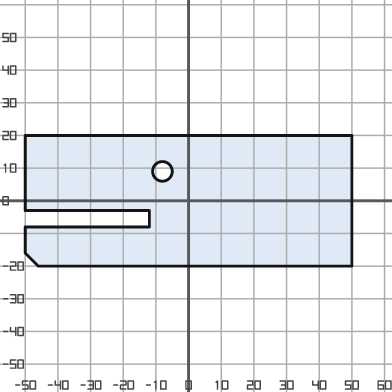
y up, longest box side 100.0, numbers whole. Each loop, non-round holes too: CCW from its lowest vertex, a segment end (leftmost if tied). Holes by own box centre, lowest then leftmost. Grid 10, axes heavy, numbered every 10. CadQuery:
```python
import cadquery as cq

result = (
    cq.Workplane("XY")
    .moveTo(-46.0, -20.0)
    .lineTo(50.0, -20.0)
    .lineTo(50.0, 20.0)
    .lineTo(-50.0, 20.0)
    .lineTo(-50.0, -3.0)
    .lineTo(-12.0, -3.0)
    .lineTo(-12.0, -8.0)
    .lineTo(-50.0, -8.0)
    .lineTo(-50.0, -16.0)
    .close()
    .moveTo(-8.0, 9.0)
    .circle(3.0)
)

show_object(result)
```